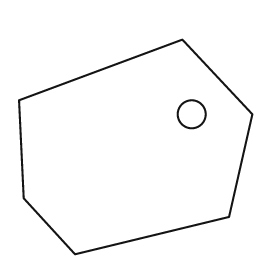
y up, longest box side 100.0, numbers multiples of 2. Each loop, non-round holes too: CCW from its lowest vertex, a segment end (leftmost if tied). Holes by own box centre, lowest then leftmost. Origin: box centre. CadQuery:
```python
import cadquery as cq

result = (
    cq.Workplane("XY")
    .moveTo(-26.0, -46.0)
    .lineTo(40.0, -30.0)
    .lineTo(50.0, 14.0)
    .lineTo(20.0, 46.0)
    .lineTo(-50.0, 20.0)
    .lineTo(-48.0, -22.0)
    .close()
    .moveTo(24.0, 14.0)
    .circle(6.0)
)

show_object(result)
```